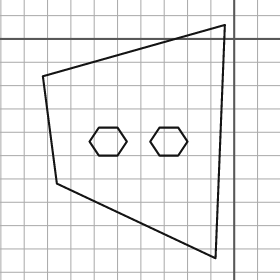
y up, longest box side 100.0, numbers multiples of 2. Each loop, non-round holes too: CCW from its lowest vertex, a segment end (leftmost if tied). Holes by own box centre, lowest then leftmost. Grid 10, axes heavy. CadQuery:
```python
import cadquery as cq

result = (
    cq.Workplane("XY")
    .moveTo(-8.0, -94.0)
    .lineTo(-4.0, 6.0)
    .lineTo(-82.0, -16.0)
    .lineTo(-76.0, -62.0)
    .close()
    .moveTo(-58.0, -50.0)
    .lineTo(-50.0, -50.0)
    .lineTo(-46.0, -44.0)
    .lineTo(-50.0, -38.0)
    .lineTo(-58.0, -38.0)
    .lineTo(-62.0, -44.0)
    .close()
    .moveTo(-32.0, -50.0)
    .lineTo(-24.0, -50.0)
    .lineTo(-20.0, -44.0)
    .lineTo(-24.0, -38.0)
    .lineTo(-32.0, -38.0)
    .lineTo(-36.0, -44.0)
    .close()
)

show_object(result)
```